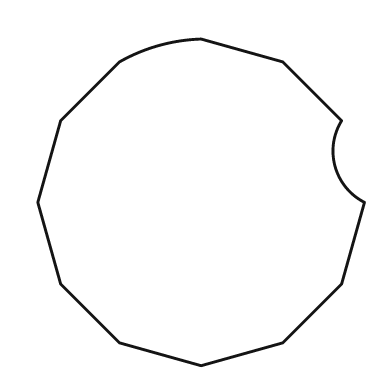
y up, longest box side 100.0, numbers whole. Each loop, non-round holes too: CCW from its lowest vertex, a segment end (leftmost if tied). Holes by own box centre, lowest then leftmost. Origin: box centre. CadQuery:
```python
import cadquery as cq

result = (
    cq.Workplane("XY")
    .moveTo(0.0, -50.0)
    .lineTo(25.0, -43.0)
    .lineTo(43.0, -25.0)
    .lineTo(50.0, 0.0)
    .threePointArc((41.0, 11.0), (43.0, 25.0))
    .lineTo(25.0, 43.0)
    .lineTo(0.0, 50.0)
    .threePointArc((-13.0, 48.0), (-25.0, 43.0))
    .lineTo(-43.0, 25.0)
    .lineTo(-50.0, 0.0)
    .lineTo(-43.0, -25.0)
    .lineTo(-25.0, -43.0)
    .close()
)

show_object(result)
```